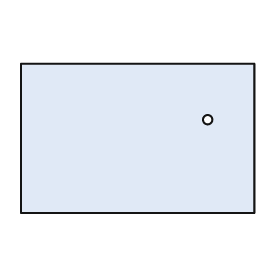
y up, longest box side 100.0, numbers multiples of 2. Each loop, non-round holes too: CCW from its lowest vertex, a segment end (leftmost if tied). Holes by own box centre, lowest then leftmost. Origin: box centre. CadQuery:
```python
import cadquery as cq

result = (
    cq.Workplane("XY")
    .moveTo(-50.0, -32.0)
    .lineTo(50.0, -32.0)
    .lineTo(50.0, 32.0)
    .lineTo(-50.0, 32.0)
    .close()
    .moveTo(30.0, 8.0)
    .circle(2.0)
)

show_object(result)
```